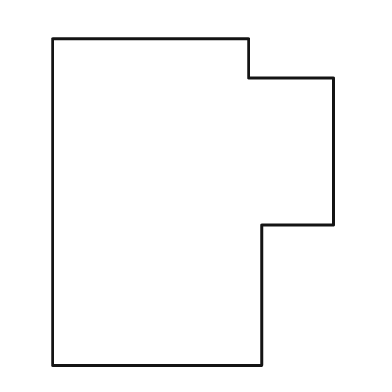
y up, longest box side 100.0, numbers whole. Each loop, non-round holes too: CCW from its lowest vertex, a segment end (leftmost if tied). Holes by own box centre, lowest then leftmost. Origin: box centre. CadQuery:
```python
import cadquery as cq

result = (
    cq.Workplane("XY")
    .moveTo(-43.0, -50.0)
    .lineTo(21.0, -50.0)
    .lineTo(21.0, -7.0)
    .lineTo(43.0, -7.0)
    .lineTo(43.0, 38.0)
    .lineTo(17.0, 38.0)
    .lineTo(17.0, 50.0)
    .lineTo(-43.0, 50.0)
    .close()
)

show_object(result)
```